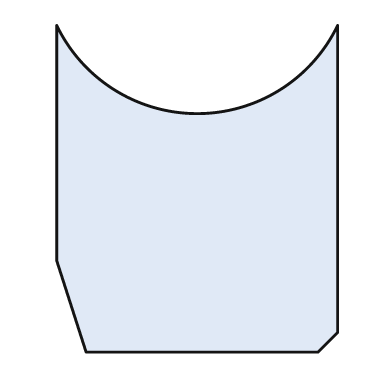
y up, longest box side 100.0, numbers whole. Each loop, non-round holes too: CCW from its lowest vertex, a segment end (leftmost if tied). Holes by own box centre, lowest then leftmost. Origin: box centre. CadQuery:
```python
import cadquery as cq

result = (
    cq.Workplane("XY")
    .moveTo(-34.0, -50.0)
    .lineTo(37.0, -50.0)
    .lineTo(43.0, -44.0)
    .lineTo(43.0, 50.0)
    .threePointArc((0.0, 23.0), (-43.0, 50.0))
    .lineTo(-43.0, -22.0)
    .close()
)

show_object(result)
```